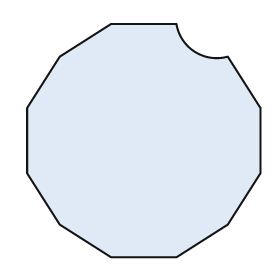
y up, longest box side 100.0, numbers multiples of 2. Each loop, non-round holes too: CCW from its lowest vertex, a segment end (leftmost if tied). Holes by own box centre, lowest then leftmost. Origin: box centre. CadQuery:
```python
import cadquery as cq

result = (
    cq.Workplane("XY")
    .moveTo(-14.0, -50.0)
    .lineTo(14.0, -50.0)
    .lineTo(36.0, -36.0)
    .lineTo(50.0, -14.0)
    .lineTo(50.0, 14.0)
    .lineTo(36.0, 36.0)
    .threePointArc((22.0, 38.0), (14.0, 50.0))
    .lineTo(-14.0, 50.0)
    .lineTo(-36.0, 36.0)
    .lineTo(-50.0, 14.0)
    .lineTo(-50.0, -14.0)
    .lineTo(-36.0, -36.0)
    .close()
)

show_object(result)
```